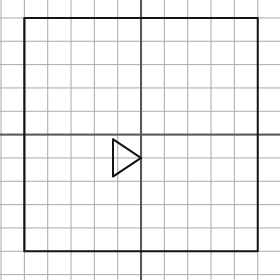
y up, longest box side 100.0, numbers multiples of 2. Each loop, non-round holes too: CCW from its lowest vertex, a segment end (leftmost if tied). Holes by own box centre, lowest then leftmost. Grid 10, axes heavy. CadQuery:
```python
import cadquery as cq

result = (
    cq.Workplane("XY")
    .moveTo(-50.0, -50.0)
    .lineTo(50.0, -50.0)
    .lineTo(50.0, 50.0)
    .lineTo(-50.0, 50.0)
    .close()
    .moveTo(-12.0, -18.0)
    .lineTo(0.0, -10.0)
    .lineTo(-12.0, -2.0)
    .close()
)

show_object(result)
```